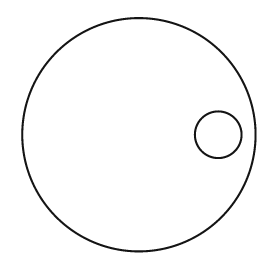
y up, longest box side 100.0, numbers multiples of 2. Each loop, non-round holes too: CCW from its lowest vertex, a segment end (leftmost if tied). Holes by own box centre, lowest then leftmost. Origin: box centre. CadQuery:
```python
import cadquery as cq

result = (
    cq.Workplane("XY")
    .moveTo(0.0, 0.0)
    .circle(50.0)
    .moveTo(34.0, 0.0)
    .circle(10.0)
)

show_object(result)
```